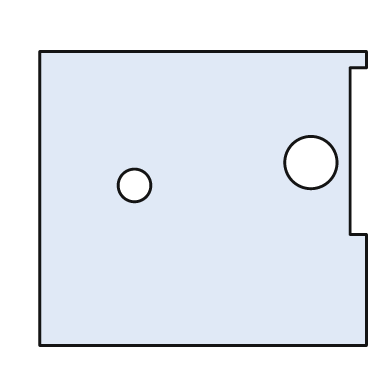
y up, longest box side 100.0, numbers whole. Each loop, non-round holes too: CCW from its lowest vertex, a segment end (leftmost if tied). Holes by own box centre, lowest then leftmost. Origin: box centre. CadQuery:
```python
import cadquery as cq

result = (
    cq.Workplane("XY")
    .moveTo(-50.0, -45.0)
    .lineTo(50.0, -45.0)
    .lineTo(50.0, -11.0)
    .lineTo(45.0, -11.0)
    .lineTo(45.0, 40.0)
    .lineTo(50.0, 40.0)
    .lineTo(50.0, 45.0)
    .lineTo(-50.0, 45.0)
    .close()
    .moveTo(-21.0, 4.0)
    .circle(5.0)
    .moveTo(33.0, 11.0)
    .circle(8.0)
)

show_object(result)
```